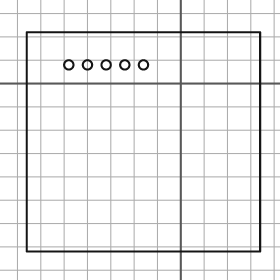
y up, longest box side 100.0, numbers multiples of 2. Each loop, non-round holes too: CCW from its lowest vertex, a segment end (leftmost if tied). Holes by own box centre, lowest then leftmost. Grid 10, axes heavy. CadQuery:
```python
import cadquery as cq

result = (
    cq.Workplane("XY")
    .moveTo(-66.0, -72.0)
    .lineTo(34.0, -72.0)
    .lineTo(34.0, 22.0)
    .lineTo(-66.0, 22.0)
    .close()
    .moveTo(-48.0, 8.0)
    .circle(2.0)
    .moveTo(-40.0, 8.0)
    .circle(2.0)
    .moveTo(-32.0, 8.0)
    .circle(2.0)
    .moveTo(-24.0, 8.0)
    .circle(2.0)
    .moveTo(-16.0, 8.0)
    .circle(2.0)
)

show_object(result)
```